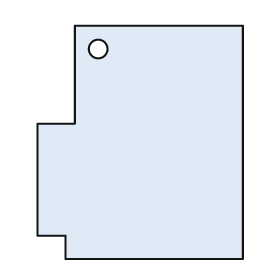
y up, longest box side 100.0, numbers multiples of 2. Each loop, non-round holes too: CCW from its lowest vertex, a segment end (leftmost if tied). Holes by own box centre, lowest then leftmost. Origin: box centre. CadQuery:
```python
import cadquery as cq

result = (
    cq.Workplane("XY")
    .moveTo(-32.0, -50.0)
    .lineTo(44.0, -50.0)
    .lineTo(44.0, 50.0)
    .lineTo(-28.0, 50.0)
    .lineTo(-28.0, 8.0)
    .lineTo(-44.0, 8.0)
    .lineTo(-44.0, -40.0)
    .lineTo(-32.0, -40.0)
    .close()
    .moveTo(-18.0, 40.0)
    .circle(4.0)
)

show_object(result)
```